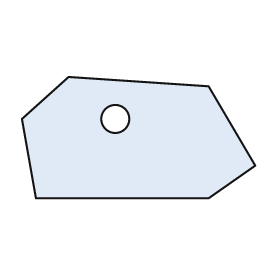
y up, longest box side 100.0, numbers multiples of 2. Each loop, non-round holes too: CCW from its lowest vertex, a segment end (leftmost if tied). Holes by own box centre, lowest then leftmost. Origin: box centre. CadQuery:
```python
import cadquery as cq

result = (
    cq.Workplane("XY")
    .moveTo(-44.0, -26.0)
    .lineTo(30.0, -26.0)
    .lineTo(50.0, -12.0)
    .lineTo(30.0, 22.0)
    .lineTo(-30.0, 26.0)
    .lineTo(-50.0, 8.0)
    .close()
    .moveTo(-10.0, 8.0)
    .circle(6.0)
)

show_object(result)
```